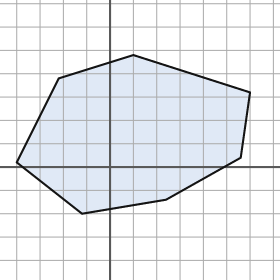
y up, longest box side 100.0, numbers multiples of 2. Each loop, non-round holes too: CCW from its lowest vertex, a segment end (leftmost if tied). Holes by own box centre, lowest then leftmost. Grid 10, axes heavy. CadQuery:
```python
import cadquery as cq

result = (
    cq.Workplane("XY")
    .moveTo(-12.0, -20.0)
    .lineTo(24.0, -14.0)
    .lineTo(56.0, 4.0)
    .lineTo(60.0, 32.0)
    .lineTo(10.0, 48.0)
    .lineTo(-22.0, 38.0)
    .lineTo(-40.0, 2.0)
    .close()
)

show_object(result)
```